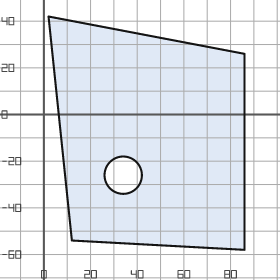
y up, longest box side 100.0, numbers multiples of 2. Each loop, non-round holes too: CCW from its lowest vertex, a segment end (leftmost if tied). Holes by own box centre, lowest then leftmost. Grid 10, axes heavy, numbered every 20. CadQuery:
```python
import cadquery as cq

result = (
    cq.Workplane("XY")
    .moveTo(86.0, -58.0)
    .lineTo(86.0, 26.0)
    .lineTo(2.0, 42.0)
    .lineTo(12.0, -54.0)
    .close()
    .moveTo(34.0, -26.0)
    .circle(8.0)
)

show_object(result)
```